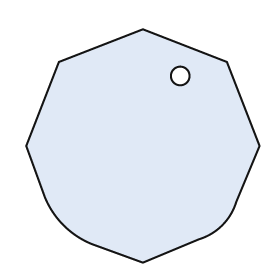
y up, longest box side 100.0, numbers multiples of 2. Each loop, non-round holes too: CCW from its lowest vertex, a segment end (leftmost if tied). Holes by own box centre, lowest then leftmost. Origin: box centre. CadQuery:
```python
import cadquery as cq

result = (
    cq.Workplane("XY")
    .moveTo(0.0, -50.0)
    .lineTo(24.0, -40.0)
    .threePointArc((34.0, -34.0), (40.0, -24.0))
    .lineTo(50.0, 0.0)
    .lineTo(36.0, 36.0)
    .lineTo(0.0, 50.0)
    .lineTo(-36.0, 36.0)
    .lineTo(-50.0, 0.0)
    .lineTo(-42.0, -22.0)
    .threePointArc((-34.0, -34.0), (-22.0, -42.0))
    .close()
    .moveTo(16.0, 30.0)
    .circle(4.0)
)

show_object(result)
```